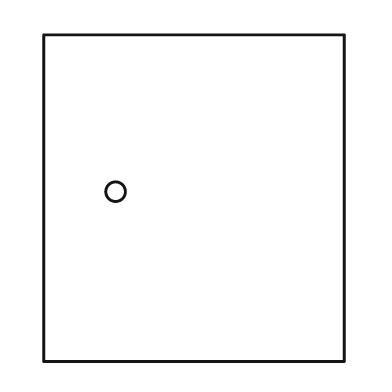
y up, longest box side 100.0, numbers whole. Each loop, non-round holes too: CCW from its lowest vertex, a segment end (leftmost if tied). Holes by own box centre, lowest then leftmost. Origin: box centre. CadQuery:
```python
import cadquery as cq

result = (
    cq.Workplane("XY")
    .moveTo(-46.0, -50.0)
    .lineTo(46.0, -50.0)
    .lineTo(46.0, 50.0)
    .lineTo(-46.0, 50.0)
    .close()
    .moveTo(-24.0, 2.0)
    .circle(3.0)
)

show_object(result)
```